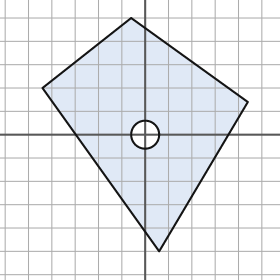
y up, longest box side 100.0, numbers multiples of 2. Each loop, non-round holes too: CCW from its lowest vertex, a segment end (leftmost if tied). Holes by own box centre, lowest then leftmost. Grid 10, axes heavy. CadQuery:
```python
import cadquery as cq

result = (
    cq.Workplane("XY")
    .moveTo(6.0, -50.0)
    .lineTo(44.0, 14.0)
    .lineTo(-6.0, 50.0)
    .lineTo(-44.0, 20.0)
    .close()
    .moveTo(0.0, 0.0)
    .circle(6.0)
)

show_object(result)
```